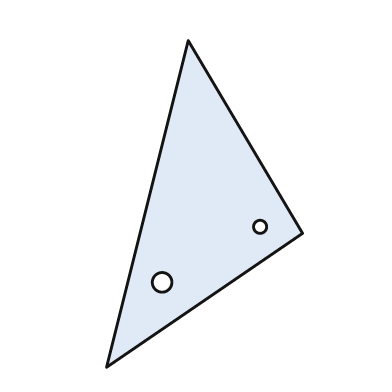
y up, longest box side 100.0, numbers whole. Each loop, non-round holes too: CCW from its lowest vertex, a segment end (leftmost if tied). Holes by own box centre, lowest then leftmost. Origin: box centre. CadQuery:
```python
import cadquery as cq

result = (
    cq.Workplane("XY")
    .moveTo(-30.0, -50.0)
    .lineTo(30.0, -9.0)
    .lineTo(-5.0, 50.0)
    .close()
    .moveTo(-13.0, -24.0)
    .circle(3.0)
    .moveTo(17.0, -7.0)
    .circle(2.0)
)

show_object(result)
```